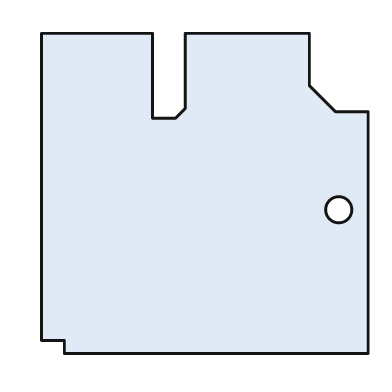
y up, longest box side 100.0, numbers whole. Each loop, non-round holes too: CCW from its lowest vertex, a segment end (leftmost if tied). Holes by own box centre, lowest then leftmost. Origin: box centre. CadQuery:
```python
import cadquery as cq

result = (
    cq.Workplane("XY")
    .moveTo(-43.0, -49.0)
    .lineTo(50.0, -49.0)
    .lineTo(50.0, 25.0)
    .lineTo(40.0, 25.0)
    .lineTo(32.0, 33.0)
    .lineTo(32.0, 49.0)
    .lineTo(-6.0, 49.0)
    .lineTo(-6.0, 26.0)
    .lineTo(-9.0, 23.0)
    .lineTo(-16.0, 23.0)
    .lineTo(-16.0, 49.0)
    .lineTo(-50.0, 49.0)
    .lineTo(-50.0, -45.0)
    .lineTo(-43.0, -45.0)
    .close()
    .moveTo(41.0, -5.0)
    .circle(4.0)
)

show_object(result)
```